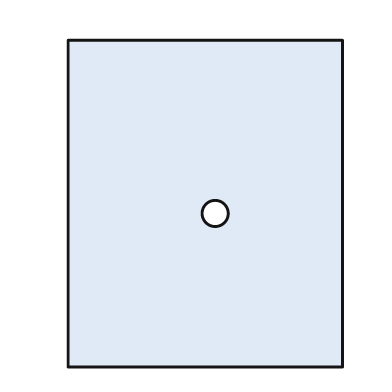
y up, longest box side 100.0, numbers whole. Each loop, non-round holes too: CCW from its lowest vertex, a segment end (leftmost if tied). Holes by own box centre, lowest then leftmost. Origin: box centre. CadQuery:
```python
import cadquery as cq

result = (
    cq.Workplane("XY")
    .moveTo(-42.0, -50.0)
    .lineTo(42.0, -50.0)
    .lineTo(42.0, 50.0)
    .lineTo(-42.0, 50.0)
    .close()
    .moveTo(3.0, -3.0)
    .circle(4.0)
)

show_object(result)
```